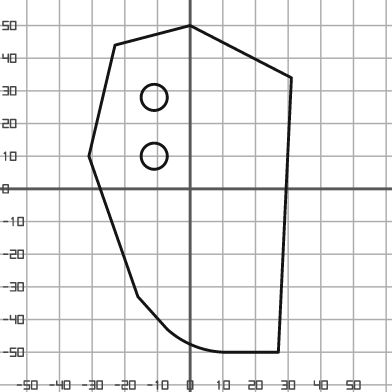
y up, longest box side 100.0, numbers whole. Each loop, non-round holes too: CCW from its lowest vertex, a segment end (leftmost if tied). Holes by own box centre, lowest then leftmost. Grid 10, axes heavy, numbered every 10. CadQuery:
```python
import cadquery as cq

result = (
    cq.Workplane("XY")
    .moveTo(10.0, -50.0)
    .lineTo(27.0, -50.0)
    .lineTo(31.0, 34.0)
    .lineTo(0.0, 50.0)
    .lineTo(-23.0, 44.0)
    .lineTo(-31.0, 10.0)
    .lineTo(-16.0, -33.0)
    .lineTo(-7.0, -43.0)
    .threePointArc((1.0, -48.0), (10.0, -50.0))
    .close()
    .moveTo(-11.0, 10.0)
    .circle(4.0)
    .moveTo(-11.0, 28.0)
    .circle(4.0)
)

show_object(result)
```